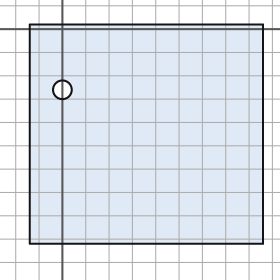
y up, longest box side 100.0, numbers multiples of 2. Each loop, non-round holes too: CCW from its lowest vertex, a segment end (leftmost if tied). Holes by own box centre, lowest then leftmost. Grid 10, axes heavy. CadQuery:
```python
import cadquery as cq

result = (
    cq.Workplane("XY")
    .moveTo(-14.0, -92.0)
    .lineTo(86.0, -92.0)
    .lineTo(86.0, 2.0)
    .lineTo(-14.0, 2.0)
    .close()
    .moveTo(0.0, -26.0)
    .circle(4.0)
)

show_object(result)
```